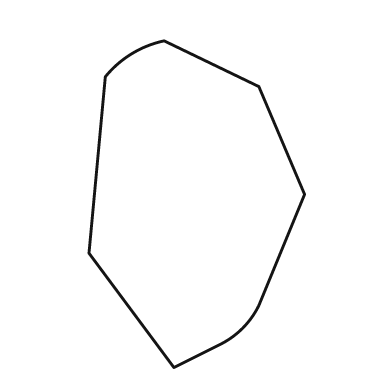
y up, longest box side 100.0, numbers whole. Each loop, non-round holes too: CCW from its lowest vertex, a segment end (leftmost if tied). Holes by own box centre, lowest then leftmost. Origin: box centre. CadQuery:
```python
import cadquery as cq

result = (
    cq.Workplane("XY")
    .moveTo(-7.0, -50.0)
    .lineTo(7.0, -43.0)
    .threePointArc((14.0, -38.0), (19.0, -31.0))
    .lineTo(33.0, 3.0)
    .lineTo(19.0, 36.0)
    .lineTo(-10.0, 50.0)
    .threePointArc((-20.0, 46.0), (-28.0, 39.0))
    .lineTo(-33.0, -15.0)
    .close()
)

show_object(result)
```